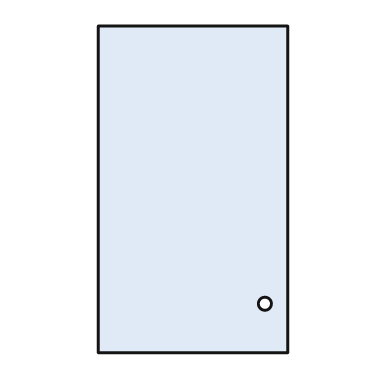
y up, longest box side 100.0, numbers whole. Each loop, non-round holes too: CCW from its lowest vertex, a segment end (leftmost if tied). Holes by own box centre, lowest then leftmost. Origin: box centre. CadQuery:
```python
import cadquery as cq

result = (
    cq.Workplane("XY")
    .moveTo(-29.0, -50.0)
    .lineTo(29.0, -50.0)
    .lineTo(29.0, 50.0)
    .lineTo(-29.0, 50.0)
    .close()
    .moveTo(22.0, -35.0)
    .circle(2.0)
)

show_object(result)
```